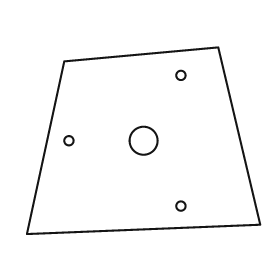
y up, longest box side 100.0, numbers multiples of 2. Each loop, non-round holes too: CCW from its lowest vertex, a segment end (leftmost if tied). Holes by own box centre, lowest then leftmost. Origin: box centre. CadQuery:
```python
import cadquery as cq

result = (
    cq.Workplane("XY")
    .moveTo(-50.0, -40.0)
    .lineTo(50.0, -36.0)
    .lineTo(32.0, 40.0)
    .lineTo(-34.0, 34.0)
    .close()
    .moveTo(16.0, -28.0)
    .circle(2.0)
    .moveTo(-32.0, 0.0)
    .circle(2.0)
    .moveTo(0.0, 0.0)
    .circle(6.0)
    .moveTo(16.0, 28.0)
    .circle(2.0)
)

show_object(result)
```